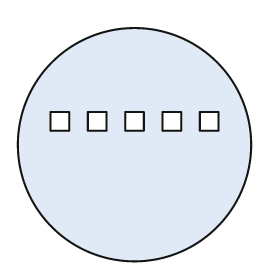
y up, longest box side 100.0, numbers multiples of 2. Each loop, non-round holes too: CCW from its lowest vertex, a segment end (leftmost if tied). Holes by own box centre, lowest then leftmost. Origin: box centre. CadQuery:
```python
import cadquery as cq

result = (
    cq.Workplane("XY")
    .moveTo(0.0, 0.0)
    .circle(50.0)
    .moveTo(-36.0, 6.0)
    .lineTo(-28.0, 6.0)
    .lineTo(-28.0, 14.0)
    .lineTo(-36.0, 14.0)
    .close()
    .moveTo(-20.0, 6.0)
    .lineTo(-12.0, 6.0)
    .lineTo(-12.0, 14.0)
    .lineTo(-20.0, 14.0)
    .close()
    .moveTo(-4.0, 6.0)
    .lineTo(4.0, 6.0)
    .lineTo(4.0, 14.0)
    .lineTo(-4.0, 14.0)
    .close()
    .moveTo(12.0, 6.0)
    .lineTo(20.0, 6.0)
    .lineTo(20.0, 14.0)
    .lineTo(12.0, 14.0)
    .close()
    .moveTo(28.0, 6.0)
    .lineTo(36.0, 6.0)
    .lineTo(36.0, 14.0)
    .lineTo(28.0, 14.0)
    .close()
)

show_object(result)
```